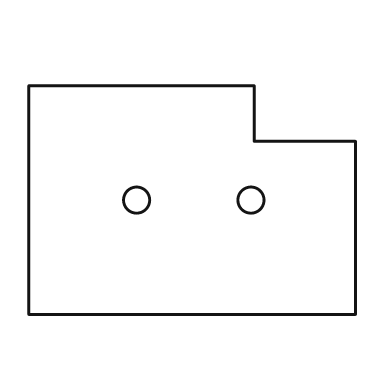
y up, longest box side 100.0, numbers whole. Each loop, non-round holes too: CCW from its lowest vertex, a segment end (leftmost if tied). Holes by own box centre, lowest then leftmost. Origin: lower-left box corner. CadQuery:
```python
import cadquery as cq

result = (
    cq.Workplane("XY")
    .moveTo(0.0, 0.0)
    .lineTo(100.0, 0.0)
    .lineTo(100.0, 53.0)
    .lineTo(69.0, 53.0)
    .lineTo(69.0, 70.0)
    .lineTo(0.0, 70.0)
    .close()
    .moveTo(33.0, 35.0)
    .circle(4.0)
    .moveTo(68.0, 35.0)
    .circle(4.0)
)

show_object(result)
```